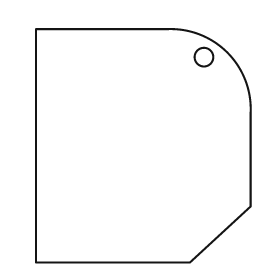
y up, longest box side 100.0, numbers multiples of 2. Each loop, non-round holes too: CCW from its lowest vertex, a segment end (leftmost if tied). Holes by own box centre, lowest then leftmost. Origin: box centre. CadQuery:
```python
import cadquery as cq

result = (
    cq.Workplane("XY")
    .moveTo(-46.0, -50.0)
    .lineTo(20.0, -50.0)
    .lineTo(46.0, -26.0)
    .lineTo(46.0, 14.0)
    .threePointArc((36.0, 40.0), (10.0, 50.0))
    .lineTo(-46.0, 50.0)
    .close()
    .moveTo(26.0, 38.0)
    .circle(4.0)
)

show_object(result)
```